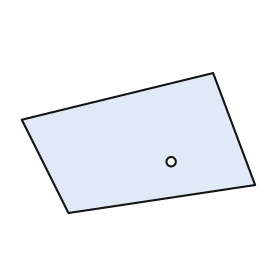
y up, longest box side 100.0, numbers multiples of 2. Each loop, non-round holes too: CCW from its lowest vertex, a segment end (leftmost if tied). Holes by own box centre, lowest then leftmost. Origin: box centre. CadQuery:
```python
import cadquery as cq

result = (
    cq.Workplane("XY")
    .moveTo(-30.0, -30.0)
    .lineTo(50.0, -18.0)
    .lineTo(32.0, 30.0)
    .lineTo(-50.0, 10.0)
    .close()
    .moveTo(14.0, -8.0)
    .circle(2.0)
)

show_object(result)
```